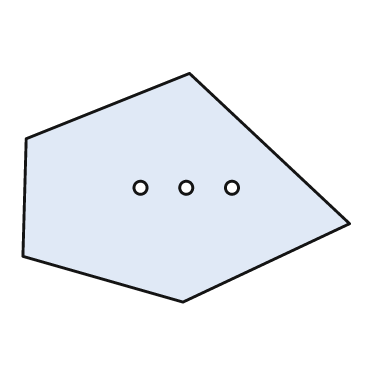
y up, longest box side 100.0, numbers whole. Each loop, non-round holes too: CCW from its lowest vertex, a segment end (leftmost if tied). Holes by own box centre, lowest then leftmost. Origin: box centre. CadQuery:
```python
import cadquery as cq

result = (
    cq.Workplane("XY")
    .moveTo(-1.0, -35.0)
    .lineTo(50.0, -11.0)
    .lineTo(1.0, 35.0)
    .lineTo(-49.0, 15.0)
    .lineTo(-50.0, -21.0)
    .close()
    .moveTo(-14.0, 0.0)
    .circle(2.0)
    .moveTo(0.0, 0.0)
    .circle(2.0)
    .moveTo(14.0, 0.0)
    .circle(2.0)
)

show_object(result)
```